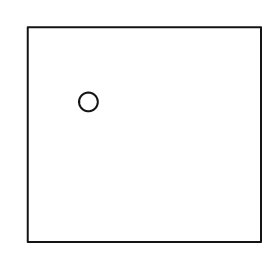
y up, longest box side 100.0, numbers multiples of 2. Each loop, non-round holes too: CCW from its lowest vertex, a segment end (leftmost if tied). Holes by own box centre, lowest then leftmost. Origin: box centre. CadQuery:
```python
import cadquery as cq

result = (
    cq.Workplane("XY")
    .moveTo(-50.0, -46.0)
    .lineTo(50.0, -46.0)
    .lineTo(50.0, 46.0)
    .lineTo(-50.0, 46.0)
    .close()
    .moveTo(-24.0, 14.0)
    .circle(4.0)
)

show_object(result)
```